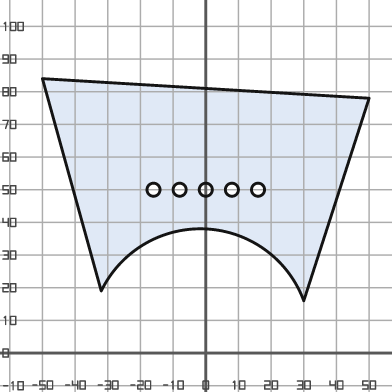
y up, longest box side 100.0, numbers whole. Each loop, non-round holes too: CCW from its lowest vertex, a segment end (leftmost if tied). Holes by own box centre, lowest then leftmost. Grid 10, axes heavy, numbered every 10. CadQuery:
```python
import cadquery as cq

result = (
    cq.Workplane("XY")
    .moveTo(30.0, 16.0)
    .lineTo(50.0, 78.0)
    .lineTo(-50.0, 84.0)
    .lineTo(-32.0, 19.0)
    .threePointArc((0.0, 38.0), (30.0, 16.0))
    .close()
    .moveTo(-16.0, 50.0)
    .circle(2.0)
    .moveTo(-8.0, 50.0)
    .circle(2.0)
    .moveTo(0.0, 50.0)
    .circle(2.0)
    .moveTo(8.0, 50.0)
    .circle(2.0)
    .moveTo(16.0, 50.0)
    .circle(2.0)
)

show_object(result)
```